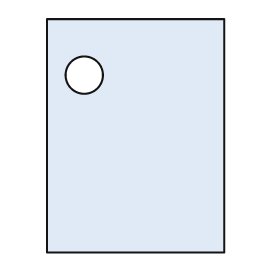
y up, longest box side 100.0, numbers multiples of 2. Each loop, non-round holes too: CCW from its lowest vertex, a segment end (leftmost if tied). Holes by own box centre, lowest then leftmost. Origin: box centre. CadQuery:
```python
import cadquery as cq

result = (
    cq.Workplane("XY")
    .moveTo(-38.0, -50.0)
    .lineTo(38.0, -50.0)
    .lineTo(38.0, 50.0)
    .lineTo(-38.0, 50.0)
    .close()
    .moveTo(-22.0, 26.0)
    .circle(8.0)
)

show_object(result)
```